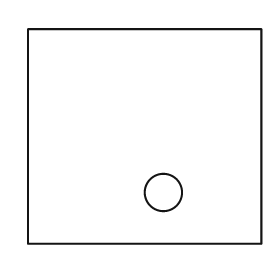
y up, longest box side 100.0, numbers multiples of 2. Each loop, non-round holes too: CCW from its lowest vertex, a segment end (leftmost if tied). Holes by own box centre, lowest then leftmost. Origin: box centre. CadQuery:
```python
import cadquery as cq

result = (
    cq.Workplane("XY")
    .moveTo(-50.0, -46.0)
    .lineTo(50.0, -46.0)
    .lineTo(50.0, 46.0)
    .lineTo(-50.0, 46.0)
    .close()
    .moveTo(8.0, -24.0)
    .circle(8.0)
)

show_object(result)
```